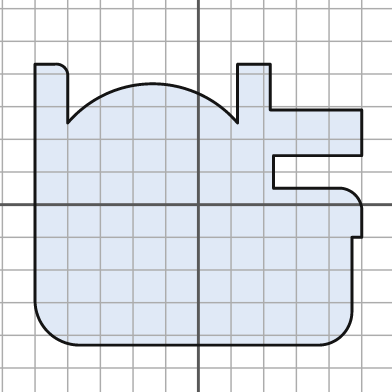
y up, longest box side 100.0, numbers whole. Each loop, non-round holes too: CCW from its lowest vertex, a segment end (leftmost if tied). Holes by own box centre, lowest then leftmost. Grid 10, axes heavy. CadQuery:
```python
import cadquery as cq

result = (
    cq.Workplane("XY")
    .moveTo(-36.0, -43.0)
    .lineTo(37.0, -43.0)
    .threePointArc((44.0, -40.0), (47.0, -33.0))
    .lineTo(47.0, -10.0)
    .lineTo(50.0, -10.0)
    .lineTo(50.0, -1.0)
    .threePointArc((48.0, 3.0), (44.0, 5.0))
    .lineTo(23.0, 5.0)
    .lineTo(23.0, 15.0)
    .lineTo(50.0, 15.0)
    .lineTo(50.0, 29.0)
    .lineTo(22.0, 29.0)
    .lineTo(22.0, 43.0)
    .lineTo(12.0, 43.0)
    .lineTo(12.0, 25.0)
    .threePointArc((-14.0, 37.0), (-40.0, 25.0))
    .lineTo(-40.0, 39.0)
    .threePointArc((-41.0, 42.0), (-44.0, 43.0))
    .lineTo(-50.0, 43.0)
    .lineTo(-50.0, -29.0)
    .threePointArc((-46.0, -39.0), (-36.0, -43.0))
    .close()
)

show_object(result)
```